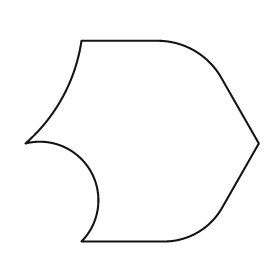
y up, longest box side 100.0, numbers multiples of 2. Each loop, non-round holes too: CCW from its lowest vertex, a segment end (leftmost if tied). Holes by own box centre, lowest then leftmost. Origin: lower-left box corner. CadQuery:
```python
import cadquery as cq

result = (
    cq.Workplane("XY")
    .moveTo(24.0, 0.0)
    .lineTo(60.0, 0.0)
    .threePointArc((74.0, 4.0), (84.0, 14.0))
    .lineTo(100.0, 42.0)
    .lineTo(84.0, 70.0)
    .threePointArc((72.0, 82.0), (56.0, 86.0))
    .lineTo(24.0, 86.0)
    .threePointArc((16.0, 62.0), (0.0, 42.0))
    .threePointArc((28.0, 30.0), (24.0, 0.0))
    .close()
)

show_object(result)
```